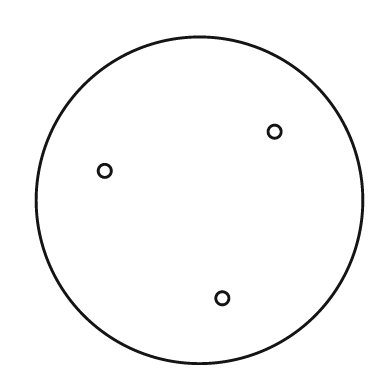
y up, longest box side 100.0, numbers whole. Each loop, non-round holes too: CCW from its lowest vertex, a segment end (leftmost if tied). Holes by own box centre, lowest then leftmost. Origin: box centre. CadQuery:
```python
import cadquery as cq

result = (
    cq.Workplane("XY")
    .moveTo(0.0, 0.0)
    .circle(50.0)
    .moveTo(7.0, -30.0)
    .circle(2.0)
    .moveTo(-29.0, 9.0)
    .circle(2.0)
    .moveTo(23.0, 21.0)
    .circle(2.0)
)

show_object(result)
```